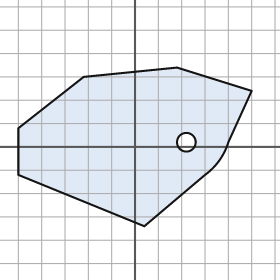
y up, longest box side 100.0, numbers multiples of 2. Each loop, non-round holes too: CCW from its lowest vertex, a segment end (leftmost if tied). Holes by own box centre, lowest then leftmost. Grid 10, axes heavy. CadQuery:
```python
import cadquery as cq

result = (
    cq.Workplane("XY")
    .moveTo(4.0, -34.0)
    .lineTo(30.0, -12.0)
    .threePointArc((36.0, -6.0), (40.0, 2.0))
    .lineTo(50.0, 24.0)
    .lineTo(18.0, 34.0)
    .lineTo(-22.0, 30.0)
    .lineTo(-50.0, 8.0)
    .lineTo(-50.0, -12.0)
    .close()
    .moveTo(22.0, 2.0)
    .circle(4.0)
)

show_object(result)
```